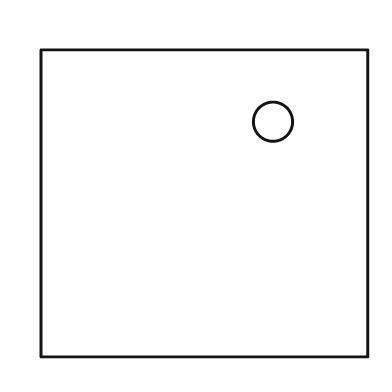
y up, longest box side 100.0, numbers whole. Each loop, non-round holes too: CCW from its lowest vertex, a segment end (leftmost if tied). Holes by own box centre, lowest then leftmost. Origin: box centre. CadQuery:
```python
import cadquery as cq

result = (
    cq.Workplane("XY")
    .moveTo(-50.0, -47.0)
    .lineTo(50.0, -47.0)
    .lineTo(50.0, 47.0)
    .lineTo(-50.0, 47.0)
    .close()
    .moveTo(21.0, 25.0)
    .circle(6.0)
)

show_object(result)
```